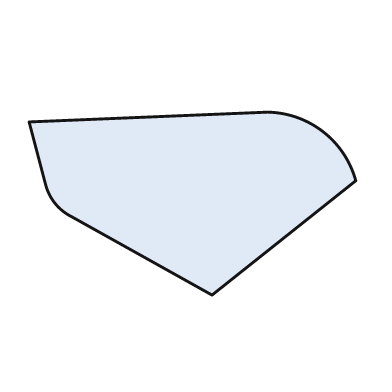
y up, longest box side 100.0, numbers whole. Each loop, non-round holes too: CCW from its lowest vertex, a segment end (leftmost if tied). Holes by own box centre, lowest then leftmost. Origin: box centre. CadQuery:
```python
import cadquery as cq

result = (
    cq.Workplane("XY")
    .moveTo(6.0, -28.0)
    .lineTo(50.0, 7.0)
    .threePointArc((40.0, 22.0), (23.0, 28.0))
    .lineTo(-50.0, 25.0)
    .lineTo(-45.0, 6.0)
    .threePointArc((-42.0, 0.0), (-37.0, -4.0))
    .close()
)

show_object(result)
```